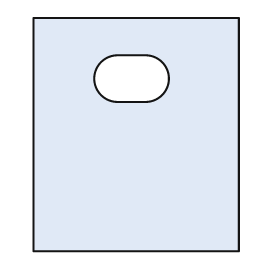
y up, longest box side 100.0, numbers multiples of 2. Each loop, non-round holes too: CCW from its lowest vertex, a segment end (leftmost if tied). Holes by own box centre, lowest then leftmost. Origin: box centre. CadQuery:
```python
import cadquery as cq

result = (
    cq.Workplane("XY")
    .moveTo(-44.0, -50.0)
    .lineTo(44.0, -50.0)
    .lineTo(44.0, 50.0)
    .lineTo(-44.0, 50.0)
    .close()
    .moveTo(-8.0, 14.0)
    .lineTo(4.0, 14.0)
    .threePointArc((14.0, 24.0), (4.0, 34.0))
    .lineTo(-8.0, 34.0)
    .threePointArc((-18.0, 24.0), (-8.0, 14.0))
    .close()
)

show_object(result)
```